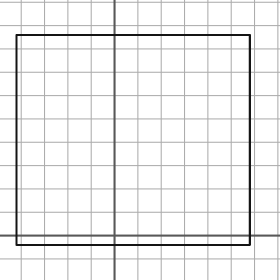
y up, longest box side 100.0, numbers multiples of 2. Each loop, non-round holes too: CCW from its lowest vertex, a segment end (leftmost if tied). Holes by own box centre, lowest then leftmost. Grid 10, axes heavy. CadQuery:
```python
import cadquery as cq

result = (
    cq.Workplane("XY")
    .moveTo(-42.0, -4.0)
    .lineTo(58.0, -4.0)
    .lineTo(58.0, 86.0)
    .lineTo(-42.0, 86.0)
    .close()
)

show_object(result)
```